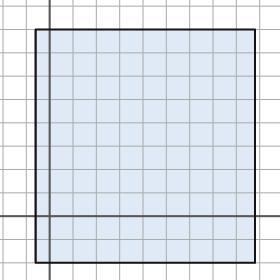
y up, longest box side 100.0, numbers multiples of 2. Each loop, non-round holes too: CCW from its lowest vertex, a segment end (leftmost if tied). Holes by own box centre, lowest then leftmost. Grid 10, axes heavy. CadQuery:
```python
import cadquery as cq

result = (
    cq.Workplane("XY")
    .moveTo(-6.0, -20.0)
    .lineTo(88.0, -20.0)
    .lineTo(88.0, 80.0)
    .lineTo(-6.0, 80.0)
    .close()
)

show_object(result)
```